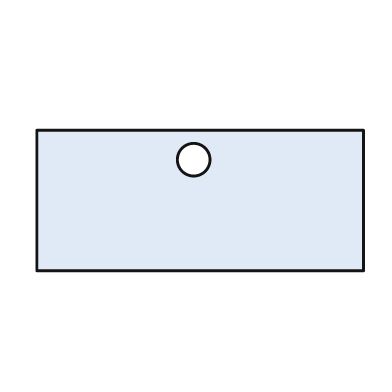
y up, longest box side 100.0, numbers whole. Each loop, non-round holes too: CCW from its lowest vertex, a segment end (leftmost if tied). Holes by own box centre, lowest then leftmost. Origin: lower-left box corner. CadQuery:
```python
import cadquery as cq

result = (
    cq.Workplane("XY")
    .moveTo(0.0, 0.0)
    .lineTo(100.0, 0.0)
    .lineTo(100.0, 43.0)
    .lineTo(0.0, 43.0)
    .close()
    .moveTo(48.0, 34.0)
    .circle(5.0)
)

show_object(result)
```